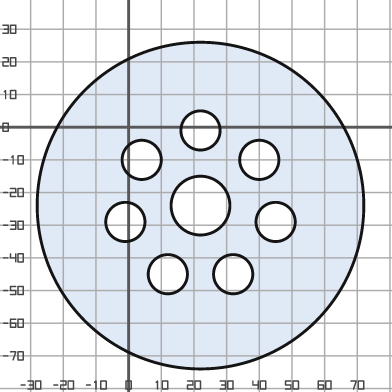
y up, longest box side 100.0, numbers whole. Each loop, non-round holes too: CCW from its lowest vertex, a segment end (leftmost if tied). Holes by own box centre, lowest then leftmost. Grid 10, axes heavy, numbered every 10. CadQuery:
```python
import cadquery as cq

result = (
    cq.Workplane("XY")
    .moveTo(22.0, -24.0)
    .circle(50.0)
    .moveTo(12.0, -45.0)
    .circle(6.0)
    .moveTo(32.0, -45.0)
    .circle(6.0)
    .moveTo(-1.0, -29.0)
    .circle(6.0)
    .moveTo(45.0, -29.0)
    .circle(6.0)
    .moveTo(22.0, -24.0)
    .circle(9.0)
    .moveTo(4.0, -10.0)
    .circle(6.0)
    .moveTo(40.0, -10.0)
    .circle(6.0)
    .moveTo(22.0, -1.0)
    .circle(6.0)
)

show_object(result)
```